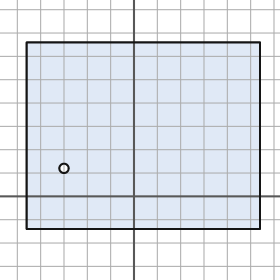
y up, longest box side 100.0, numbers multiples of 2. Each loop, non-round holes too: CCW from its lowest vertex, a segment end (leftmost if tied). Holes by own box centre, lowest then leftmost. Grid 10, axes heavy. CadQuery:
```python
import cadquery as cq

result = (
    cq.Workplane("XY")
    .moveTo(-46.0, -14.0)
    .lineTo(54.0, -14.0)
    .lineTo(54.0, 66.0)
    .lineTo(-46.0, 66.0)
    .close()
    .moveTo(-30.0, 12.0)
    .circle(2.0)
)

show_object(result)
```